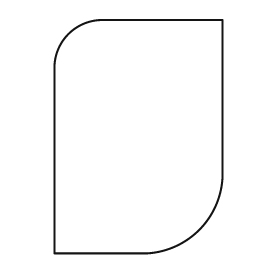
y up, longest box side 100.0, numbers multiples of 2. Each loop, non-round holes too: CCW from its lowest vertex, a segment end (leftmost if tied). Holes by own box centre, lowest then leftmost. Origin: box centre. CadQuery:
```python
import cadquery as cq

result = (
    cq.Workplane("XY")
    .moveTo(-36.0, -50.0)
    .lineTo(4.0, -50.0)
    .threePointArc((26.0, -40.0), (36.0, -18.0))
    .lineTo(36.0, 50.0)
    .lineTo(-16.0, 50.0)
    .threePointArc((-30.0, 44.0), (-36.0, 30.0))
    .close()
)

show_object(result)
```